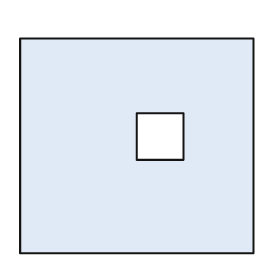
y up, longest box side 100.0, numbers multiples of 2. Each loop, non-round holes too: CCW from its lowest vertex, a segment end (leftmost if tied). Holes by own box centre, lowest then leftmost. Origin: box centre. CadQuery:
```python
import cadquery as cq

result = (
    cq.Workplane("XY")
    .moveTo(-50.0, -46.0)
    .lineTo(50.0, -46.0)
    .lineTo(50.0, 46.0)
    .lineTo(-50.0, 46.0)
    .close()
    .moveTo(0.0, -6.0)
    .lineTo(20.0, -6.0)
    .lineTo(20.0, 14.0)
    .lineTo(0.0, 14.0)
    .close()
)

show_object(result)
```